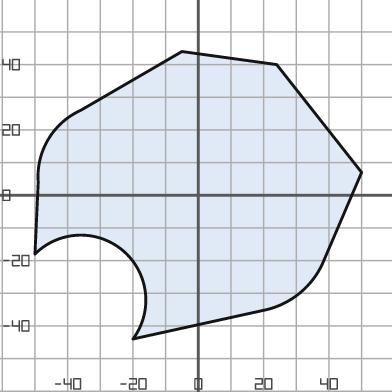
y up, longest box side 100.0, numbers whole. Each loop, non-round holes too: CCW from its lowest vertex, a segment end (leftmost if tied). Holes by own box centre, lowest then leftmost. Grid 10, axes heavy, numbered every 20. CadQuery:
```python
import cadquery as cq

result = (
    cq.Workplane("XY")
    .moveTo(-20.0, -44.0)
    .lineTo(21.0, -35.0)
    .threePointArc((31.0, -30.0), (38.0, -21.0))
    .lineTo(50.0, 7.0)
    .lineTo(24.0, 40.0)
    .lineTo(-5.0, 44.0)
    .lineTo(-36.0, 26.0)
    .threePointArc((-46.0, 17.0), (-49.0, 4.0))
    .lineTo(-50.0, -18.0)
    .threePointArc((-23.0, -17.0), (-20.0, -44.0))
    .close()
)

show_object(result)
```